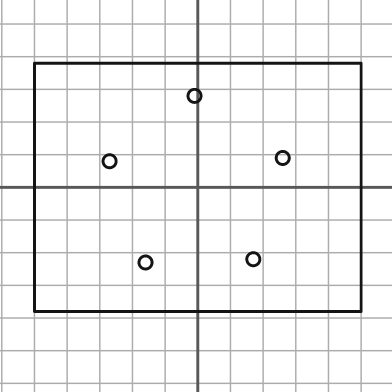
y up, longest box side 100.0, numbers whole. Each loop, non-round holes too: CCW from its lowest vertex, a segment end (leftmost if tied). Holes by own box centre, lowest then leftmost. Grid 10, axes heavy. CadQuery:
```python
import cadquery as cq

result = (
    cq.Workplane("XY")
    .moveTo(-50.0, -38.0)
    .lineTo(50.0, -38.0)
    .lineTo(50.0, 38.0)
    .lineTo(-50.0, 38.0)
    .close()
    .moveTo(-16.0, -23.0)
    .circle(2.0)
    .moveTo(17.0, -22.0)
    .circle(2.0)
    .moveTo(-27.0, 8.0)
    .circle(2.0)
    .moveTo(26.0, 9.0)
    .circle(2.0)
    .moveTo(-1.0, 28.0)
    .circle(2.0)
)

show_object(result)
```